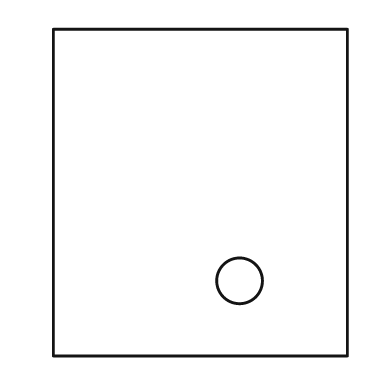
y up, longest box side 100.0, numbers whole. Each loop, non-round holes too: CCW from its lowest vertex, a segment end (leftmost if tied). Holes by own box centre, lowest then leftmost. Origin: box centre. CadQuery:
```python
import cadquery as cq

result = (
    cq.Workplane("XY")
    .moveTo(-45.0, -50.0)
    .lineTo(45.0, -50.0)
    .lineTo(45.0, 50.0)
    .lineTo(-45.0, 50.0)
    .close()
    .moveTo(12.0, -27.0)
    .circle(7.0)
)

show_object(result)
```